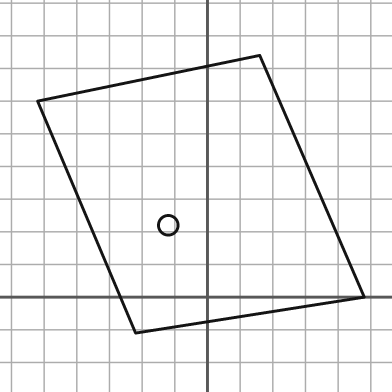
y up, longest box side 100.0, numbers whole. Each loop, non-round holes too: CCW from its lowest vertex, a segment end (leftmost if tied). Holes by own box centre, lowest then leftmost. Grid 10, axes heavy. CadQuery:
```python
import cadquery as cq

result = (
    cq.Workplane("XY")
    .moveTo(-22.0, -11.0)
    .lineTo(48.0, 0.0)
    .lineTo(16.0, 74.0)
    .lineTo(-52.0, 60.0)
    .close()
    .moveTo(-12.0, 22.0)
    .circle(3.0)
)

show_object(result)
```